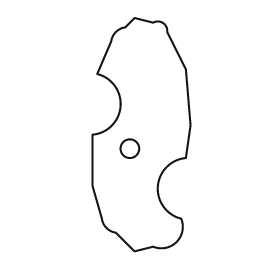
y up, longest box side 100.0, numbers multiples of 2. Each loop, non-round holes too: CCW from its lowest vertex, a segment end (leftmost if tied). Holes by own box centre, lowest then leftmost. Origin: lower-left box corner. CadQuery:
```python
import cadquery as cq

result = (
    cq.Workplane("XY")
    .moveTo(18.0, 0.0)
    .lineTo(26.0, 2.0)
    .threePointArc((36.0, 4.0), (38.0, 14.0))
    .threePointArc((28.0, 28.0), (40.0, 40.0))
    .lineTo(42.0, 54.0)
    .lineTo(40.0, 78.0)
    .lineTo(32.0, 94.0)
    .threePointArc((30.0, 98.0), (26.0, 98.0))
    .lineTo(18.0, 100.0)
    .lineTo(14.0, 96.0)
    .threePointArc((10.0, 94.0), (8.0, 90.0))
    .lineTo(2.0, 76.0)
    .threePointArc((12.0, 62.0), (0.0, 50.0))
    .lineTo(0.0, 28.0)
    .lineTo(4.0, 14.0)
    .threePointArc((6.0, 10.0), (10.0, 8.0))
    .close()
    .moveTo(16.0, 44.0)
    .circle(4.0)
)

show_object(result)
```